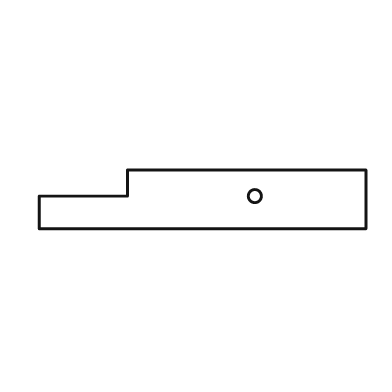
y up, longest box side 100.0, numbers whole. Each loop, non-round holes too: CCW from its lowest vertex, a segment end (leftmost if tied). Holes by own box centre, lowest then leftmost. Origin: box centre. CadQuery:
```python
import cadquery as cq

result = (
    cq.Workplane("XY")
    .moveTo(-50.0, -9.0)
    .lineTo(50.0, -9.0)
    .lineTo(50.0, 9.0)
    .lineTo(-23.0, 9.0)
    .lineTo(-23.0, 1.0)
    .lineTo(-50.0, 1.0)
    .close()
    .moveTo(16.0, 1.0)
    .circle(2.0)
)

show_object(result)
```